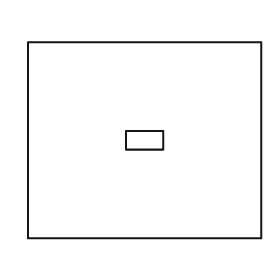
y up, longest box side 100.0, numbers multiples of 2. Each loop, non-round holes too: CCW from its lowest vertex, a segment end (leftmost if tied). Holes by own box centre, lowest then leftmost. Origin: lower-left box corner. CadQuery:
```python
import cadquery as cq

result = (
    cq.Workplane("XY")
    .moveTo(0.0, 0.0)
    .lineTo(100.0, 0.0)
    .lineTo(100.0, 84.0)
    .lineTo(0.0, 84.0)
    .close()
    .moveTo(42.0, 38.0)
    .lineTo(58.0, 38.0)
    .lineTo(58.0, 46.0)
    .lineTo(42.0, 46.0)
    .close()
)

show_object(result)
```